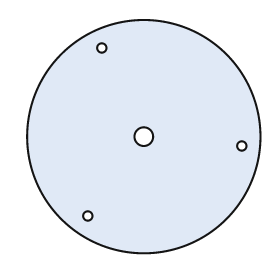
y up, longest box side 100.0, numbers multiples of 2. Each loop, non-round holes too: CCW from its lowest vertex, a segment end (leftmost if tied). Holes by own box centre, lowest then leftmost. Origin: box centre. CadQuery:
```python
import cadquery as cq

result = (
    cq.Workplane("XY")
    .moveTo(0.0, 0.0)
    .circle(50.0)
    .moveTo(-24.0, -34.0)
    .circle(2.0)
    .moveTo(42.0, -4.0)
    .circle(2.0)
    .moveTo(0.0, 0.0)
    .circle(4.0)
    .moveTo(-18.0, 38.0)
    .circle(2.0)
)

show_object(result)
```